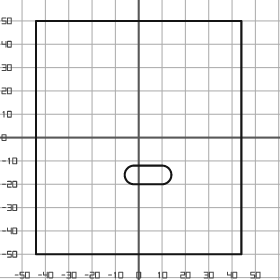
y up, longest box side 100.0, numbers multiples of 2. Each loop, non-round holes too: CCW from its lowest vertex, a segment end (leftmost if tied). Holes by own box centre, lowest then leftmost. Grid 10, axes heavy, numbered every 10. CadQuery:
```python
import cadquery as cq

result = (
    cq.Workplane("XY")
    .moveTo(-44.0, -50.0)
    .lineTo(44.0, -50.0)
    .lineTo(44.0, 50.0)
    .lineTo(-44.0, 50.0)
    .close()
    .moveTo(-2.0, -20.0)
    .lineTo(10.0, -20.0)
    .threePointArc((14.0, -16.0), (10.0, -12.0))
    .lineTo(-2.0, -12.0)
    .threePointArc((-6.0, -16.0), (-2.0, -20.0))
    .close()
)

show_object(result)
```